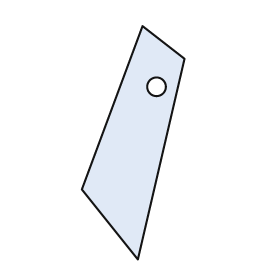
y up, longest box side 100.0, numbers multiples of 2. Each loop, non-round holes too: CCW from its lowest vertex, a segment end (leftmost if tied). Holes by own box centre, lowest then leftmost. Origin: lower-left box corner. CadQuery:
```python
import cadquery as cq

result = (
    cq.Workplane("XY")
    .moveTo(24.0, 0.0)
    .lineTo(44.0, 86.0)
    .lineTo(26.0, 100.0)
    .lineTo(0.0, 30.0)
    .close()
    .moveTo(32.0, 74.0)
    .circle(4.0)
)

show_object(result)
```